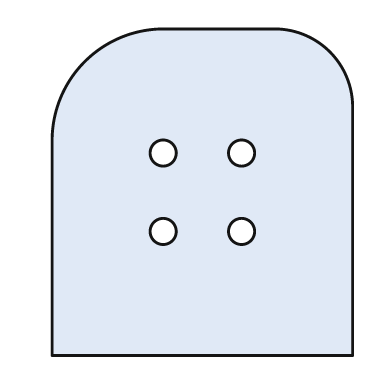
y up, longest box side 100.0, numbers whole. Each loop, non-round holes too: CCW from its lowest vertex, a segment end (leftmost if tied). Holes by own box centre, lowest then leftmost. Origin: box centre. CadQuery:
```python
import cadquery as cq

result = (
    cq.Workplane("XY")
    .moveTo(-46.0, -50.0)
    .lineTo(46.0, -50.0)
    .lineTo(46.0, 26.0)
    .threePointArc((39.0, 43.0), (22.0, 50.0))
    .lineTo(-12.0, 50.0)
    .threePointArc((-36.0, 40.0), (-46.0, 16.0))
    .close()
    .moveTo(-12.0, -12.0)
    .circle(4.0)
    .moveTo(12.0, -12.0)
    .circle(4.0)
    .moveTo(-12.0, 12.0)
    .circle(4.0)
    .moveTo(12.0, 12.0)
    .circle(4.0)
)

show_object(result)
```